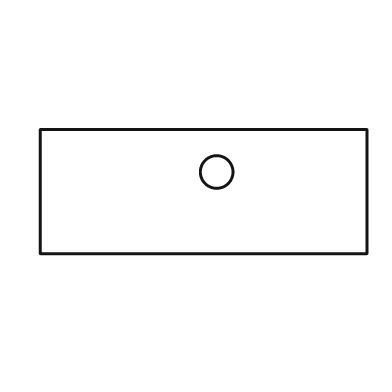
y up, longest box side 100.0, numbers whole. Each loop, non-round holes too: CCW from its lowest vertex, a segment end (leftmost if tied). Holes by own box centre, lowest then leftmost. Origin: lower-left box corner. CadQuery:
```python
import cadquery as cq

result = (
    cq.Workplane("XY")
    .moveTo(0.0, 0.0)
    .lineTo(100.0, 0.0)
    .lineTo(100.0, 38.0)
    .lineTo(0.0, 38.0)
    .close()
    .moveTo(54.0, 25.0)
    .circle(5.0)
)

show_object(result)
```